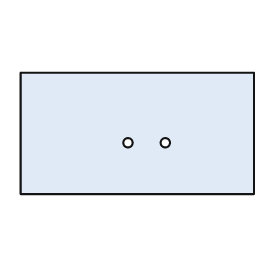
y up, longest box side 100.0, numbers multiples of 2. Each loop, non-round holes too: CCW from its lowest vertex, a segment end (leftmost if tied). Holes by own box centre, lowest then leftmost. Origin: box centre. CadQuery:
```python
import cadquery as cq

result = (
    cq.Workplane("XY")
    .moveTo(-50.0, -26.0)
    .lineTo(50.0, -26.0)
    .lineTo(50.0, 26.0)
    .lineTo(-50.0, 26.0)
    .close()
    .moveTo(-4.0, -4.0)
    .circle(2.0)
    .moveTo(12.0, -4.0)
    .circle(2.0)
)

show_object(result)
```